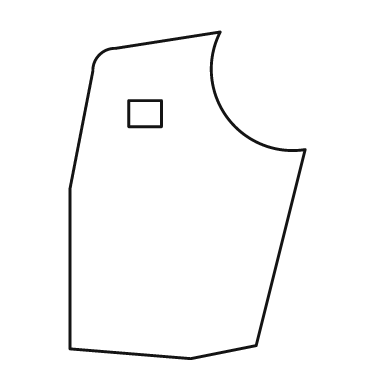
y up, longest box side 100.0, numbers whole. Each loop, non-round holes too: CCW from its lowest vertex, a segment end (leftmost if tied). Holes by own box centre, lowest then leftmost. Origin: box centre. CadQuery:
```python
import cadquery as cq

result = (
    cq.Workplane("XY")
    .moveTo(1.0, -50.0)
    .lineTo(21.0, -46.0)
    .lineTo(36.0, 14.0)
    .threePointArc((12.0, 24.0), (10.0, 50.0))
    .lineTo(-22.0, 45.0)
    .threePointArc((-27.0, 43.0), (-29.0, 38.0))
    .lineTo(-36.0, 2.0)
    .lineTo(-36.0, -47.0)
    .close()
    .moveTo(-18.0, 21.0)
    .lineTo(-8.0, 21.0)
    .lineTo(-8.0, 29.0)
    .lineTo(-18.0, 29.0)
    .close()
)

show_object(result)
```